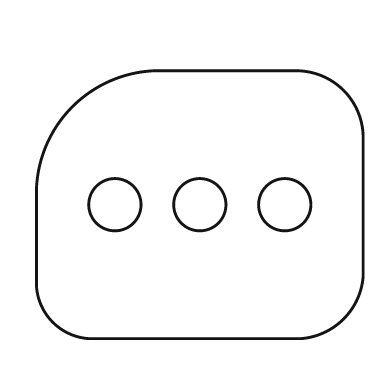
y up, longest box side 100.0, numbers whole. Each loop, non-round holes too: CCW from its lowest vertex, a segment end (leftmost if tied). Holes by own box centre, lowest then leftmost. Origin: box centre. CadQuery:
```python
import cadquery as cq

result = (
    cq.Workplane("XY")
    .moveTo(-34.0, -41.0)
    .lineTo(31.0, -41.0)
    .threePointArc((44.0, -35.0), (50.0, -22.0))
    .lineTo(50.0, 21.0)
    .threePointArc((44.0, 35.0), (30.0, 41.0))
    .lineTo(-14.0, 41.0)
    .threePointArc((-39.0, 30.0), (-50.0, 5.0))
    .lineTo(-50.0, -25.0)
    .threePointArc((-45.0, -36.0), (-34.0, -41.0))
    .close()
    .moveTo(-26.0, 0.0)
    .circle(8.0)
    .moveTo(0.0, 0.0)
    .circle(8.0)
    .moveTo(26.0, 0.0)
    .circle(8.0)
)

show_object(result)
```